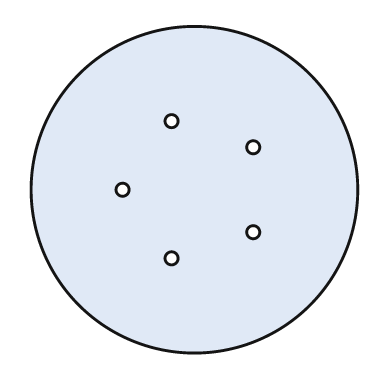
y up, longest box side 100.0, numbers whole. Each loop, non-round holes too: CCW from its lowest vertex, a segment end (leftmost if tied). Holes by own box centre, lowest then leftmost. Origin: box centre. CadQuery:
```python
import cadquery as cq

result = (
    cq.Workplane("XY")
    .moveTo(0.0, 0.0)
    .circle(50.0)
    .moveTo(-7.0, -21.0)
    .circle(2.0)
    .moveTo(18.0, -13.0)
    .circle(2.0)
    .moveTo(-22.0, 0.0)
    .circle(2.0)
    .moveTo(18.0, 13.0)
    .circle(2.0)
    .moveTo(-7.0, 21.0)
    .circle(2.0)
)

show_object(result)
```